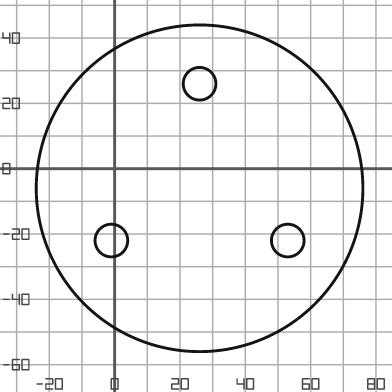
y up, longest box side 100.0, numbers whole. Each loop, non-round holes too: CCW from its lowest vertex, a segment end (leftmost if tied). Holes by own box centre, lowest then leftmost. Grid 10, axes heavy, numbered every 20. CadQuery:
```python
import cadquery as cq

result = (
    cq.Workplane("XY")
    .moveTo(26.0, -6.0)
    .circle(50.0)
    .moveTo(-1.0, -22.0)
    .circle(5.0)
    .moveTo(53.0, -22.0)
    .circle(5.0)
    .moveTo(26.0, 26.0)
    .circle(5.0)
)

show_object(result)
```